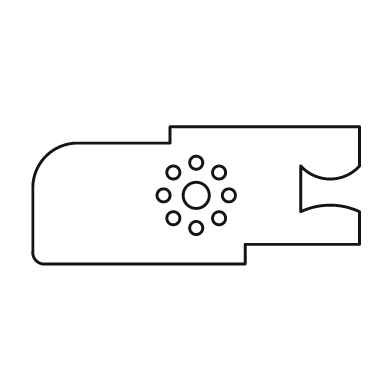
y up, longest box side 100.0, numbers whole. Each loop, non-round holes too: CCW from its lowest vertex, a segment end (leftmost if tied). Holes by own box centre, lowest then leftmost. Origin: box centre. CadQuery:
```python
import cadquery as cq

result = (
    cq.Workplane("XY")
    .moveTo(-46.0, -21.0)
    .lineTo(15.0, -21.0)
    .lineTo(15.0, -15.0)
    .lineTo(50.0, -15.0)
    .lineTo(50.0, -5.0)
    .threePointArc((41.0, -3.0), (32.0, -5.0))
    .lineTo(32.0, 9.0)
    .threePointArc((41.0, 5.0), (50.0, 9.0))
    .lineTo(50.0, 21.0)
    .lineTo(-8.0, 21.0)
    .lineTo(-8.0, 16.0)
    .lineTo(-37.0, 16.0)
    .threePointArc((-46.0, 12.0), (-50.0, 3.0))
    .lineTo(-50.0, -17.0)
    .threePointArc((-49.0, -20.0), (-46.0, -21.0))
    .close()
    .moveTo(0.0, -10.0)
    .circle(2.0)
    .moveTo(-7.0, -7.0)
    .circle(2.0)
    .moveTo(7.0, -7.0)
    .circle(2.0)
    .moveTo(-10.0, 0.0)
    .circle(2.0)
    .moveTo(0.0, 0.0)
    .circle(4.0)
    .moveTo(10.0, 0.0)
    .circle(2.0)
    .moveTo(-7.0, 7.0)
    .circle(2.0)
    .moveTo(7.0, 7.0)
    .circle(2.0)
    .moveTo(0.0, 10.0)
    .circle(2.0)
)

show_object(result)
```